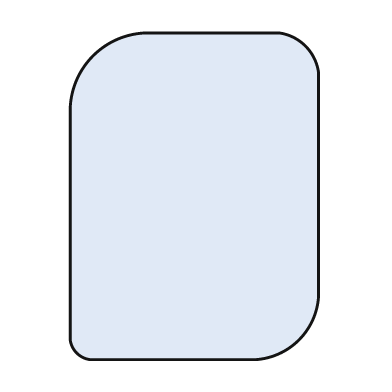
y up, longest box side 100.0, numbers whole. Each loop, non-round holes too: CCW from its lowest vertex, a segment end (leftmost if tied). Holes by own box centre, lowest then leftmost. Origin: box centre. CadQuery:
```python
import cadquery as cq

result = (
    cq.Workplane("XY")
    .moveTo(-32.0, -50.0)
    .lineTo(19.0, -50.0)
    .threePointArc((32.0, -44.0), (38.0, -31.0))
    .lineTo(38.0, 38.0)
    .threePointArc((34.0, 46.0), (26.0, 50.0))
    .lineTo(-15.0, 50.0)
    .threePointArc((-31.0, 43.0), (-38.0, 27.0))
    .lineTo(-38.0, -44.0)
    .threePointArc((-36.0, -48.0), (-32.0, -50.0))
    .close()
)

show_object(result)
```